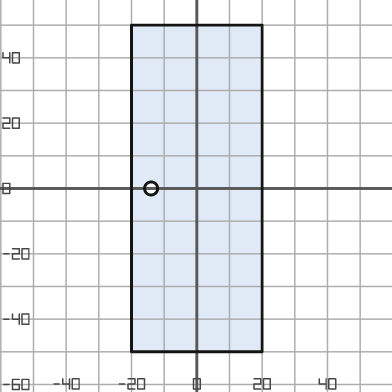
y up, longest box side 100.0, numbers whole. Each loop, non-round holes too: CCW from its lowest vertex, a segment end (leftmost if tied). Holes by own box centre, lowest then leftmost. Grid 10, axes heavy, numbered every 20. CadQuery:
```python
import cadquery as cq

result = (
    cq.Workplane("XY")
    .moveTo(-20.0, -50.0)
    .lineTo(20.0, -50.0)
    .lineTo(20.0, 50.0)
    .lineTo(-20.0, 50.0)
    .close()
    .moveTo(-14.0, 0.0)
    .circle(2.0)
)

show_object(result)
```